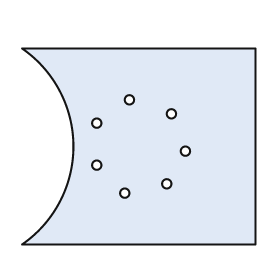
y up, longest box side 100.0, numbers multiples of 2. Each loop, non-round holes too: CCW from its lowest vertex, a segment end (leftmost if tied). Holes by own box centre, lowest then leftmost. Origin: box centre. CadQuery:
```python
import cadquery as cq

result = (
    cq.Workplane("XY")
    .moveTo(-50.0, -42.0)
    .lineTo(50.0, -42.0)
    .lineTo(50.0, 42.0)
    .lineTo(-50.0, 42.0)
    .threePointArc((-28.0, 0.0), (-50.0, -42.0))
    .close()
    .moveTo(-6.0, -20.0)
    .circle(2.0)
    .moveTo(12.0, -16.0)
    .circle(2.0)
    .moveTo(-18.0, -8.0)
    .circle(2.0)
    .moveTo(20.0, -2.0)
    .circle(2.0)
    .moveTo(-18.0, 10.0)
    .circle(2.0)
    .moveTo(14.0, 14.0)
    .circle(2.0)
    .moveTo(-4.0, 20.0)
    .circle(2.0)
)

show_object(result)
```